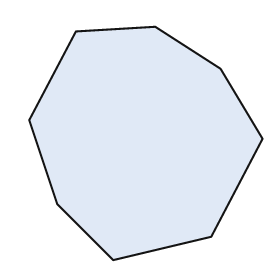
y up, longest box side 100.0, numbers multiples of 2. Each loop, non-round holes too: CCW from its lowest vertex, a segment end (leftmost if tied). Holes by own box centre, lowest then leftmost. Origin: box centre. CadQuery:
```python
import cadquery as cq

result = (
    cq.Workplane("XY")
    .moveTo(-14.0, -50.0)
    .lineTo(28.0, -40.0)
    .lineTo(50.0, 2.0)
    .lineTo(32.0, 32.0)
    .lineTo(4.0, 50.0)
    .lineTo(-30.0, 48.0)
    .lineTo(-50.0, 10.0)
    .lineTo(-38.0, -26.0)
    .close()
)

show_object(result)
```